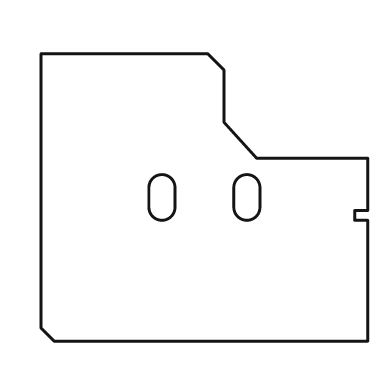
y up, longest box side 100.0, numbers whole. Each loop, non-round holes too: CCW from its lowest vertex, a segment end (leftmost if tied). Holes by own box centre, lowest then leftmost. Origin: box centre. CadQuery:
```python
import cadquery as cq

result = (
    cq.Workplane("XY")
    .moveTo(-46.0, -44.0)
    .lineTo(50.0, -44.0)
    .lineTo(50.0, -7.0)
    .lineTo(46.0, -7.0)
    .lineTo(46.0, -4.0)
    .lineTo(50.0, -4.0)
    .lineTo(50.0, 12.0)
    .lineTo(16.0, 12.0)
    .lineTo(6.0, 23.0)
    .lineTo(6.0, 39.0)
    .lineTo(1.0, 44.0)
    .lineTo(-50.0, 44.0)
    .lineTo(-50.0, -40.0)
    .close()
    .moveTo(-17.0, -3.0)
    .threePointArc((-13.0, -7.0), (-9.0, -3.0))
    .lineTo(-9.0, 3.0)
    .threePointArc((-13.0, 7.0), (-17.0, 3.0))
    .close()
    .moveTo(9.0, -3.0)
    .threePointArc((13.0, -7.0), (17.0, -3.0))
    .lineTo(17.0, 3.0)
    .threePointArc((13.0, 7.0), (9.0, 3.0))
    .close()
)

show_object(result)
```